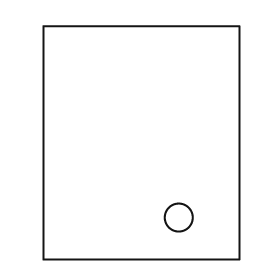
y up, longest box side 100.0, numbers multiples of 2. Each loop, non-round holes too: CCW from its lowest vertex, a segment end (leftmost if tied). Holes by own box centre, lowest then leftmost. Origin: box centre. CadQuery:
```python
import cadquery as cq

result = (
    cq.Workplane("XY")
    .moveTo(-42.0, -50.0)
    .lineTo(42.0, -50.0)
    .lineTo(42.0, 50.0)
    .lineTo(-42.0, 50.0)
    .close()
    .moveTo(16.0, -32.0)
    .circle(6.0)
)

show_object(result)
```